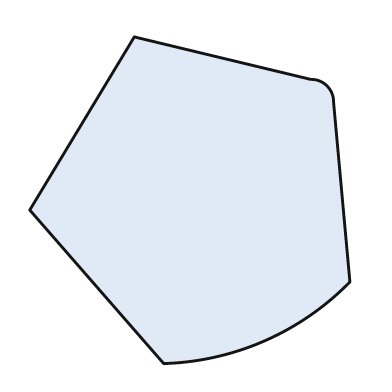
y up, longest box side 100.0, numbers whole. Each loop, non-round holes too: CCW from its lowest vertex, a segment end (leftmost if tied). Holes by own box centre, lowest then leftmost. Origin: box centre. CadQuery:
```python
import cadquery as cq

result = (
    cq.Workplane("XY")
    .moveTo(-8.0, -50.0)
    .threePointArc((23.0, -43.0), (49.0, -25.0))
    .lineTo(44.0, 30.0)
    .threePointArc((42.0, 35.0), (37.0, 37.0))
    .lineTo(-17.0, 50.0)
    .lineTo(-49.0, -3.0)
    .close()
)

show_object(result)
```